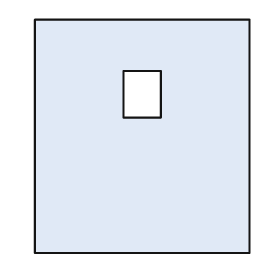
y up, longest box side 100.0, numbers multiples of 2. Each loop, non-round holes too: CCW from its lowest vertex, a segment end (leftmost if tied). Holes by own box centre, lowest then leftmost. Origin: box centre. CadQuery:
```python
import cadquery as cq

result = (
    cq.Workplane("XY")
    .moveTo(-46.0, -50.0)
    .lineTo(46.0, -50.0)
    .lineTo(46.0, 50.0)
    .lineTo(-46.0, 50.0)
    .close()
    .moveTo(-8.0, 8.0)
    .lineTo(8.0, 8.0)
    .lineTo(8.0, 28.0)
    .lineTo(-8.0, 28.0)
    .close()
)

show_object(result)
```